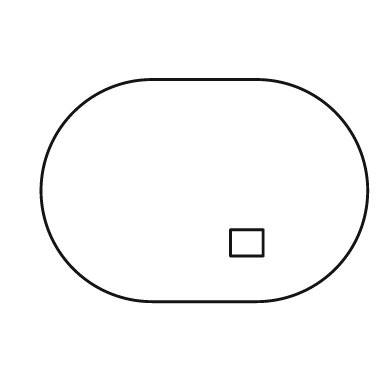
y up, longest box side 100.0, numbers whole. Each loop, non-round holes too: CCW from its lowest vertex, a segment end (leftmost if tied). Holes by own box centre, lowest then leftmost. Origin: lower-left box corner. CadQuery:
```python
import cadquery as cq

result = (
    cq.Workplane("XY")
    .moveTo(34.0, 0.0)
    .lineTo(66.0, 0.0)
    .threePointArc((100.0, 34.0), (66.0, 68.0))
    .lineTo(34.0, 68.0)
    .threePointArc((0.0, 34.0), (34.0, 0.0))
    .close()
    .moveTo(58.0, 14.0)
    .lineTo(68.0, 14.0)
    .lineTo(68.0, 22.0)
    .lineTo(58.0, 22.0)
    .close()
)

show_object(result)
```